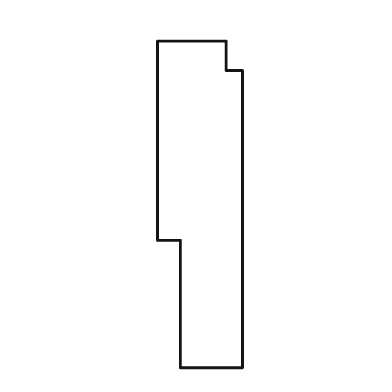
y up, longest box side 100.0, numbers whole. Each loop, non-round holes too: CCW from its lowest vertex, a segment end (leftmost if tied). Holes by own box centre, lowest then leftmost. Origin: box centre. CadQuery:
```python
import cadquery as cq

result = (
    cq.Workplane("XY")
    .moveTo(-6.0, -50.0)
    .lineTo(13.0, -50.0)
    .lineTo(13.0, 41.0)
    .lineTo(8.0, 41.0)
    .lineTo(8.0, 50.0)
    .lineTo(-13.0, 50.0)
    .lineTo(-13.0, -11.0)
    .lineTo(-6.0, -11.0)
    .close()
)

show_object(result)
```